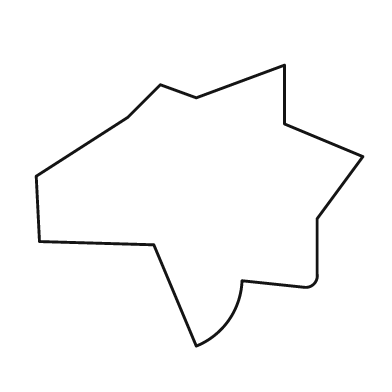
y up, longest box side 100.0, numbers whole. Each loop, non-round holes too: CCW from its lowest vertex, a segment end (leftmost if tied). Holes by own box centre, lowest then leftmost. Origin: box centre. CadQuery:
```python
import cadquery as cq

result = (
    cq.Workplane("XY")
    .moveTo(-1.0, -43.0)
    .threePointArc((9.0, -35.0), (13.0, -23.0))
    .lineTo(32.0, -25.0)
    .threePointArc((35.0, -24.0), (36.0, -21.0))
    .lineTo(36.0, -4.0)
    .lineTo(50.0, 15.0)
    .lineTo(26.0, 25.0)
    .lineTo(26.0, 43.0)
    .lineTo(-1.0, 33.0)
    .lineTo(-12.0, 37.0)
    .lineTo(-22.0, 27.0)
    .lineTo(-50.0, 9.0)
    .lineTo(-49.0, -11.0)
    .lineTo(-14.0, -12.0)
    .close()
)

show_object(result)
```